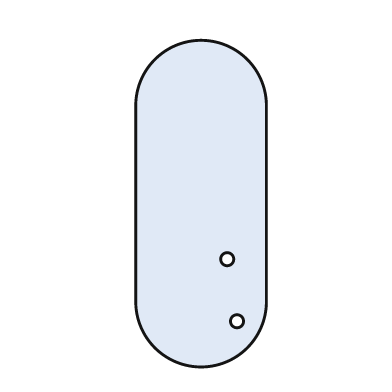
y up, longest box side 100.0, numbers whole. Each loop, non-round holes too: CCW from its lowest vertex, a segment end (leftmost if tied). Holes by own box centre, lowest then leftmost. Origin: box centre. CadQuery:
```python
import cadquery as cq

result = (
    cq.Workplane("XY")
    .moveTo(-20.0, -30.0)
    .threePointArc((0.0, -50.0), (20.0, -30.0))
    .lineTo(20.0, 30.0)
    .threePointArc((0.0, 50.0), (-20.0, 30.0))
    .close()
    .moveTo(11.0, -36.0)
    .circle(2.0)
    .moveTo(8.0, -17.0)
    .circle(2.0)
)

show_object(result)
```